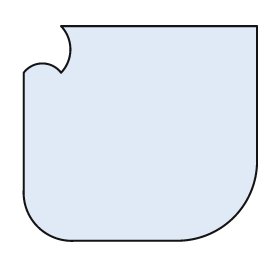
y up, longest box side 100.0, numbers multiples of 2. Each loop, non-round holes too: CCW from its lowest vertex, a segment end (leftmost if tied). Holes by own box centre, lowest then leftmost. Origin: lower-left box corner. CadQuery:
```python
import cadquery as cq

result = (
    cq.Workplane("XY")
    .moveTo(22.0, 0.0)
    .lineTo(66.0, 0.0)
    .threePointArc((90.0, 10.0), (100.0, 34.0))
    .lineTo(100.0, 92.0)
    .lineTo(16.0, 92.0)
    .threePointArc((20.0, 82.0), (16.0, 72.0))
    .threePointArc((8.0, 76.0), (0.0, 72.0))
    .lineTo(0.0, 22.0)
    .threePointArc((6.0, 6.0), (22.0, 0.0))
    .close()
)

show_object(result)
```